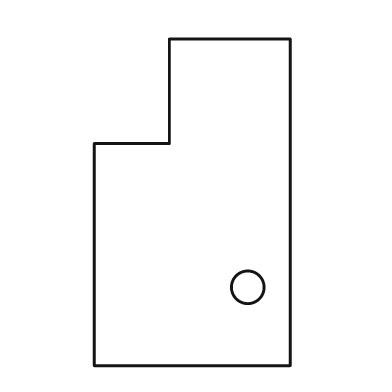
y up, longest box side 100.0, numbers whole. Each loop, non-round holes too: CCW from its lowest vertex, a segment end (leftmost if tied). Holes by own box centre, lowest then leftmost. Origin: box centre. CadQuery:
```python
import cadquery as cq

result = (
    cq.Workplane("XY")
    .moveTo(-30.0, -50.0)
    .lineTo(30.0, -50.0)
    .lineTo(30.0, 50.0)
    .lineTo(-7.0, 50.0)
    .lineTo(-7.0, 18.0)
    .lineTo(-30.0, 18.0)
    .close()
    .moveTo(17.0, -26.0)
    .circle(5.0)
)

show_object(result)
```